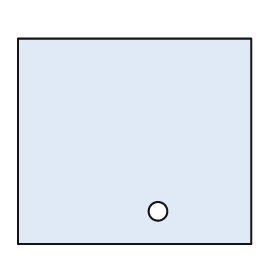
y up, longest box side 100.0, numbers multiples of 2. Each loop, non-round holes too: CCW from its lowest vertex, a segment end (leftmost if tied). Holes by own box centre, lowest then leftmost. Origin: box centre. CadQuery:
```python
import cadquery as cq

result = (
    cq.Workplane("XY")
    .moveTo(-50.0, -44.0)
    .lineTo(50.0, -44.0)
    .lineTo(50.0, 44.0)
    .lineTo(-50.0, 44.0)
    .close()
    .moveTo(10.0, -30.0)
    .circle(4.0)
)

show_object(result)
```